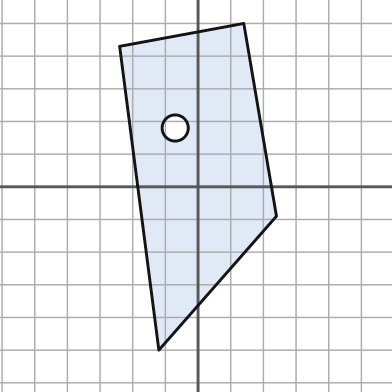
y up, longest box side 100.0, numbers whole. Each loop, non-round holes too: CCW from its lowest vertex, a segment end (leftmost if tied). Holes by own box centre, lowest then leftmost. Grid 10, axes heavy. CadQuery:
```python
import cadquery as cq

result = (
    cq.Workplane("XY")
    .moveTo(-12.0, -50.0)
    .lineTo(24.0, -9.0)
    .lineTo(14.0, 50.0)
    .lineTo(-24.0, 43.0)
    .close()
    .moveTo(-7.0, 18.0)
    .circle(4.0)
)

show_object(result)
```